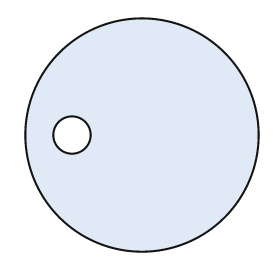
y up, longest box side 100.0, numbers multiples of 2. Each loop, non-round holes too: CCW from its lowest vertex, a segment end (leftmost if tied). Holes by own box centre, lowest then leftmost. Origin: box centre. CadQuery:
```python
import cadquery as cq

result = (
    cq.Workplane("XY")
    .moveTo(0.0, 0.0)
    .circle(50.0)
    .moveTo(-30.0, 0.0)
    .circle(8.0)
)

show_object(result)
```